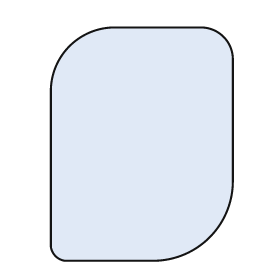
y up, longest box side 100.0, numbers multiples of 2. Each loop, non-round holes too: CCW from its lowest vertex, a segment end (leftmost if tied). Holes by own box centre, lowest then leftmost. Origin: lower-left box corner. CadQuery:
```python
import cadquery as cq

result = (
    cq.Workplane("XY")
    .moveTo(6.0, 0.0)
    .lineTo(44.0, 0.0)
    .threePointArc((68.0, 10.0), (78.0, 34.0))
    .lineTo(78.0, 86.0)
    .threePointArc((74.0, 96.0), (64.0, 100.0))
    .lineTo(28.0, 100.0)
    .threePointArc((8.0, 92.0), (0.0, 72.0))
    .lineTo(0.0, 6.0)
    .threePointArc((2.0, 2.0), (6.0, 0.0))
    .close()
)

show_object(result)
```